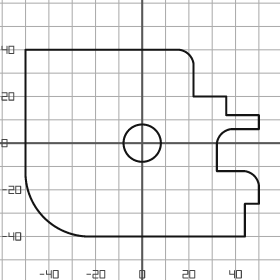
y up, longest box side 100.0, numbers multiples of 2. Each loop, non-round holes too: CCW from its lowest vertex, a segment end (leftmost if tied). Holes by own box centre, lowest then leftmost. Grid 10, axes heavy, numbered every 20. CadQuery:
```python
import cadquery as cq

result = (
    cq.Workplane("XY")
    .moveTo(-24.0, -40.0)
    .lineTo(44.0, -40.0)
    .lineTo(44.0, -26.0)
    .lineTo(50.0, -26.0)
    .lineTo(50.0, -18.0)
    .threePointArc((48.0, -14.0), (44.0, -12.0))
    .lineTo(32.0, -12.0)
    .lineTo(32.0, 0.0)
    .threePointArc((34.0, 4.0), (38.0, 6.0))
    .lineTo(50.0, 6.0)
    .lineTo(50.0, 12.0)
    .lineTo(36.0, 12.0)
    .lineTo(36.0, 20.0)
    .lineTo(22.0, 20.0)
    .lineTo(22.0, 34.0)
    .threePointArc((20.0, 38.0), (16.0, 40.0))
    .lineTo(-50.0, 40.0)
    .lineTo(-50.0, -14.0)
    .threePointArc((-42.0, -32.0), (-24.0, -40.0))
    .close()
    .moveTo(0.0, 0.0)
    .circle(8.0)
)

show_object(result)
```